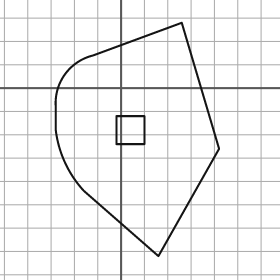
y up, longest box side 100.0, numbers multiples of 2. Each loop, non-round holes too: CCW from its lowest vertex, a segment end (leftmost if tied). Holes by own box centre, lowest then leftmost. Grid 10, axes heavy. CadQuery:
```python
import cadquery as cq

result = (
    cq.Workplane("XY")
    .moveTo(16.0, -72.0)
    .lineTo(42.0, -26.0)
    .lineTo(26.0, 28.0)
    .lineTo(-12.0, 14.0)
    .threePointArc((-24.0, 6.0), (-28.0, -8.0))
    .lineTo(-28.0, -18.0)
    .threePointArc((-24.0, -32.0), (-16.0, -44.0))
    .close()
    .moveTo(-2.0, -24.0)
    .lineTo(10.0, -24.0)
    .lineTo(10.0, -12.0)
    .lineTo(-2.0, -12.0)
    .close()
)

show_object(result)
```